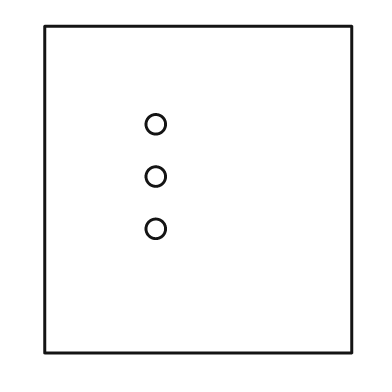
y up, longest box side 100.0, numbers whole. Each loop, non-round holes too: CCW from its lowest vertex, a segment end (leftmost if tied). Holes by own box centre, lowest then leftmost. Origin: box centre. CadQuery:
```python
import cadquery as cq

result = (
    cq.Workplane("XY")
    .moveTo(-47.0, -50.0)
    .lineTo(47.0, -50.0)
    .lineTo(47.0, 50.0)
    .lineTo(-47.0, 50.0)
    .close()
    .moveTo(-13.0, -12.0)
    .circle(3.0)
    .moveTo(-13.0, 4.0)
    .circle(3.0)
    .moveTo(-13.0, 20.0)
    .circle(3.0)
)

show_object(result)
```